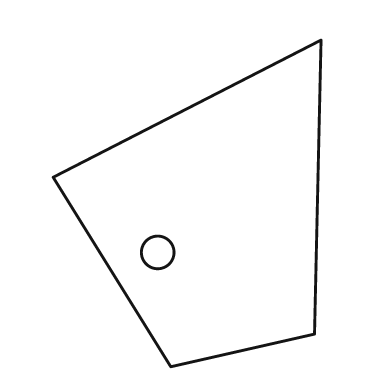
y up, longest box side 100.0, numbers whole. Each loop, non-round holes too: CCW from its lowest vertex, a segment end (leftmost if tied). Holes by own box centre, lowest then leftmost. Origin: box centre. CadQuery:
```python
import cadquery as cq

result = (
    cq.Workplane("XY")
    .moveTo(-5.0, -50.0)
    .lineTo(39.0, -40.0)
    .lineTo(41.0, 50.0)
    .lineTo(-41.0, 8.0)
    .close()
    .moveTo(-9.0, -15.0)
    .circle(5.0)
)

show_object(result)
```